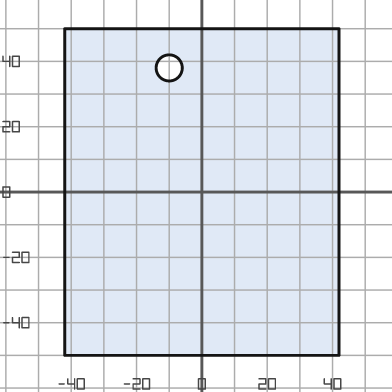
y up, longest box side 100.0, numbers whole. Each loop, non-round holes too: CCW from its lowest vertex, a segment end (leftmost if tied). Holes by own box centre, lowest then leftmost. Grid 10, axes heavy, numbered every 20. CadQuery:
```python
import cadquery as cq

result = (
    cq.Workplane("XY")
    .moveTo(-42.0, -50.0)
    .lineTo(42.0, -50.0)
    .lineTo(42.0, 50.0)
    .lineTo(-42.0, 50.0)
    .close()
    .moveTo(-10.0, 38.0)
    .circle(4.0)
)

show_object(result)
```